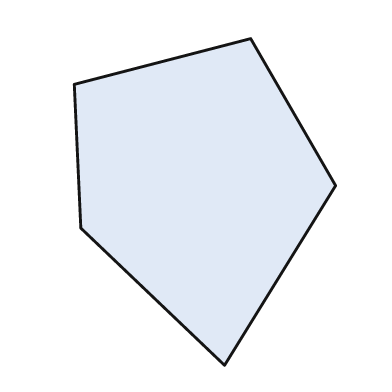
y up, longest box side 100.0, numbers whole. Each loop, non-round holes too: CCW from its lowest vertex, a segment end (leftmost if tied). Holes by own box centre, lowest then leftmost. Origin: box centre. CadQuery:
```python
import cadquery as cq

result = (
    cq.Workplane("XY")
    .moveTo(6.0, -50.0)
    .lineTo(40.0, 5.0)
    .lineTo(14.0, 50.0)
    .lineTo(-40.0, 36.0)
    .lineTo(-38.0, -8.0)
    .close()
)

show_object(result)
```